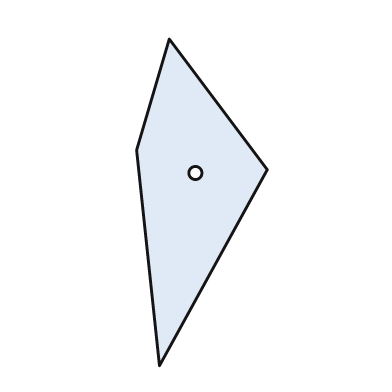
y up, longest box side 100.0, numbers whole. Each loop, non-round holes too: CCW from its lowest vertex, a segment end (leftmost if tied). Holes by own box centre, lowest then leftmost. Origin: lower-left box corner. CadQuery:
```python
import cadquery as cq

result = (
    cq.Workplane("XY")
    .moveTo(7.0, 0.0)
    .lineTo(40.0, 60.0)
    .lineTo(10.0, 100.0)
    .lineTo(0.0, 66.0)
    .close()
    .moveTo(18.0, 59.0)
    .circle(2.0)
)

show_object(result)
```